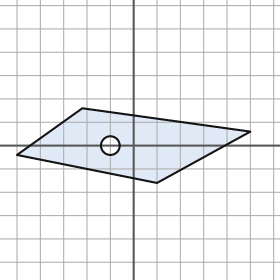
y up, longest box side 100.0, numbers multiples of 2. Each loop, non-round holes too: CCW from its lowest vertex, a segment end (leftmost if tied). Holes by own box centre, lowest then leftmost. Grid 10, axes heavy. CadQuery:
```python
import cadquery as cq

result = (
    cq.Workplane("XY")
    .moveTo(10.0, -16.0)
    .lineTo(50.0, 6.0)
    .lineTo(-22.0, 16.0)
    .lineTo(-50.0, -4.0)
    .close()
    .moveTo(-10.0, 0.0)
    .circle(4.0)
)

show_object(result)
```